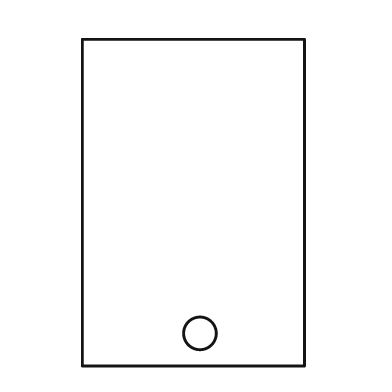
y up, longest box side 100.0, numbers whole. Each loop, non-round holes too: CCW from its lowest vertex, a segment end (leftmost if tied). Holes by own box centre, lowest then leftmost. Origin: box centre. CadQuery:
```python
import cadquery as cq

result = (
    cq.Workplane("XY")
    .moveTo(-34.0, -50.0)
    .lineTo(34.0, -50.0)
    .lineTo(34.0, 50.0)
    .lineTo(-34.0, 50.0)
    .close()
    .moveTo(2.0, -40.0)
    .circle(5.0)
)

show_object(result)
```